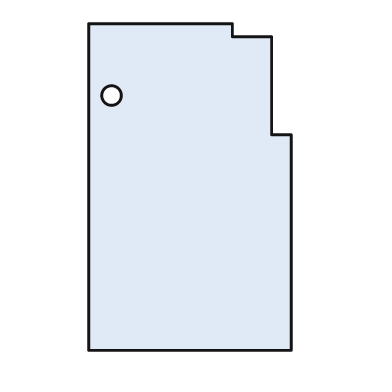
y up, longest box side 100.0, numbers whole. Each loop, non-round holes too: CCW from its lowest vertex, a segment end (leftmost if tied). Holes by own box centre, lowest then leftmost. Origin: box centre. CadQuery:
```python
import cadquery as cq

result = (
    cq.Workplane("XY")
    .moveTo(-31.0, -50.0)
    .lineTo(31.0, -50.0)
    .lineTo(31.0, 16.0)
    .lineTo(25.0, 16.0)
    .lineTo(25.0, 46.0)
    .lineTo(13.0, 46.0)
    .lineTo(13.0, 50.0)
    .lineTo(-31.0, 50.0)
    .close()
    .moveTo(-24.0, 28.0)
    .circle(3.0)
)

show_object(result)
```